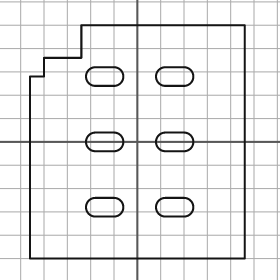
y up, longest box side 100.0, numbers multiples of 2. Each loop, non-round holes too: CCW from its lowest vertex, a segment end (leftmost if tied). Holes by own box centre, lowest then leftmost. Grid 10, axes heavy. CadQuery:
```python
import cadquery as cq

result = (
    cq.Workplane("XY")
    .moveTo(-46.0, -50.0)
    .lineTo(46.0, -50.0)
    .lineTo(46.0, 50.0)
    .lineTo(-24.0, 50.0)
    .lineTo(-24.0, 36.0)
    .lineTo(-40.0, 36.0)
    .lineTo(-40.0, 28.0)
    .lineTo(-46.0, 28.0)
    .close()
    .moveTo(-18.0, -32.0)
    .lineTo(-10.0, -32.0)
    .threePointArc((-6.0, -28.0), (-10.0, -24.0))
    .lineTo(-18.0, -24.0)
    .threePointArc((-22.0, -28.0), (-18.0, -32.0))
    .close()
    .moveTo(12.0, -32.0)
    .lineTo(20.0, -32.0)
    .threePointArc((24.0, -28.0), (20.0, -24.0))
    .lineTo(12.0, -24.0)
    .threePointArc((8.0, -28.0), (12.0, -32.0))
    .close()
    .moveTo(-18.0, -4.0)
    .lineTo(-10.0, -4.0)
    .threePointArc((-6.0, 0.0), (-10.0, 4.0))
    .lineTo(-18.0, 4.0)
    .threePointArc((-22.0, 0.0), (-18.0, -4.0))
    .close()
    .moveTo(12.0, -4.0)
    .lineTo(20.0, -4.0)
    .threePointArc((24.0, 0.0), (20.0, 4.0))
    .lineTo(12.0, 4.0)
    .threePointArc((8.0, 0.0), (12.0, -4.0))
    .close()
    .moveTo(-18.0, 24.0)
    .lineTo(-10.0, 24.0)
    .threePointArc((-6.0, 28.0), (-10.0, 32.0))
    .lineTo(-18.0, 32.0)
    .threePointArc((-22.0, 28.0), (-18.0, 24.0))
    .close()
    .moveTo(12.0, 24.0)
    .lineTo(20.0, 24.0)
    .threePointArc((24.0, 28.0), (20.0, 32.0))
    .lineTo(12.0, 32.0)
    .threePointArc((8.0, 28.0), (12.0, 24.0))
    .close()
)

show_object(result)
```